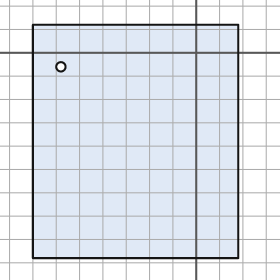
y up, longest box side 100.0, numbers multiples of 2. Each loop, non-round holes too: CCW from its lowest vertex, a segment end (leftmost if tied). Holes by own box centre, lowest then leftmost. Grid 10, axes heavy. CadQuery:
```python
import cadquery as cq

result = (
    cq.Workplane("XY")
    .moveTo(-70.0, -88.0)
    .lineTo(18.0, -88.0)
    .lineTo(18.0, 12.0)
    .lineTo(-70.0, 12.0)
    .close()
    .moveTo(-58.0, -6.0)
    .circle(2.0)
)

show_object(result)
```